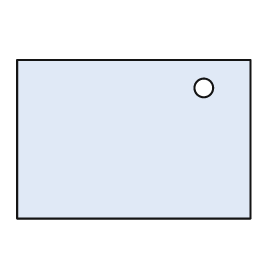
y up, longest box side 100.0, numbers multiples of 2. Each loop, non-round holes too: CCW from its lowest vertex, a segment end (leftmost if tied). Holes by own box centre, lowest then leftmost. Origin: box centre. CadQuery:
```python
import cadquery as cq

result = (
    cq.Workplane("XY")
    .moveTo(-50.0, -34.0)
    .lineTo(50.0, -34.0)
    .lineTo(50.0, 34.0)
    .lineTo(-50.0, 34.0)
    .close()
    .moveTo(30.0, 22.0)
    .circle(4.0)
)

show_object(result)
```